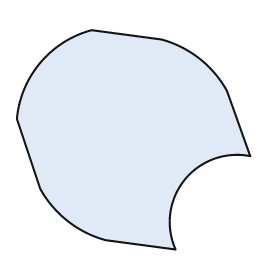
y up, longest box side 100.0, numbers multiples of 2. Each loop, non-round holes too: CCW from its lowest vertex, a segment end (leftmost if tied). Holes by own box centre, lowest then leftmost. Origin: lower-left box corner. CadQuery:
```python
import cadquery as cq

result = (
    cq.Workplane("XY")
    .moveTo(68.0, 0.0)
    .threePointArc((72.0, 30.0), (100.0, 40.0))
    .lineTo(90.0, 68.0)
    .threePointArc((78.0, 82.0), (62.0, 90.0))
    .lineTo(32.0, 94.0)
    .threePointArc((10.0, 80.0), (0.0, 56.0))
    .lineTo(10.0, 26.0)
    .threePointArc((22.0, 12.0), (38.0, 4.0))
    .close()
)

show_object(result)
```